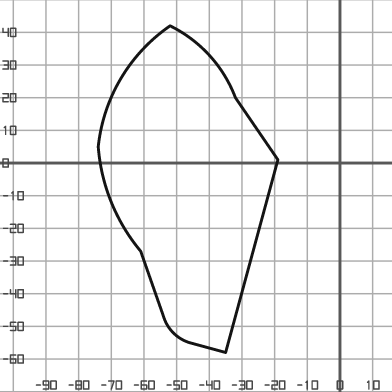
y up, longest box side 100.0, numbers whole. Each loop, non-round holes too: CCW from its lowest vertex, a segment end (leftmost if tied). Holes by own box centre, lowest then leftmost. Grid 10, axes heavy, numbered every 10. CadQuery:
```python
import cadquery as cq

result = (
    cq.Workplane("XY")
    .moveTo(-35.0, -58.0)
    .lineTo(-19.0, 1.0)
    .lineTo(-32.0, 20.0)
    .threePointArc((-40.0, 33.0), (-52.0, 42.0))
    .threePointArc((-67.0, 26.0), (-74.0, 5.0))
    .threePointArc((-70.0, -12.0), (-61.0, -27.0))
    .lineTo(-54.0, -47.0)
    .threePointArc((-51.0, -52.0), (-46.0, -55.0))
    .close()
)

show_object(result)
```